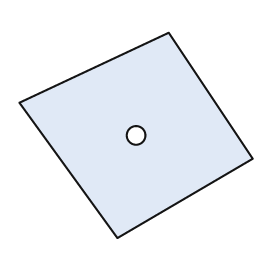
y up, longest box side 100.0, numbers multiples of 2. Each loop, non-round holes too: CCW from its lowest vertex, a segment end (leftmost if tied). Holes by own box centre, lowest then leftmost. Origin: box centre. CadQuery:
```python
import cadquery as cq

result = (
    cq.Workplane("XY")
    .moveTo(-8.0, -44.0)
    .lineTo(50.0, -10.0)
    .lineTo(14.0, 44.0)
    .lineTo(-50.0, 14.0)
    .close()
    .moveTo(0.0, 0.0)
    .circle(4.0)
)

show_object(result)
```